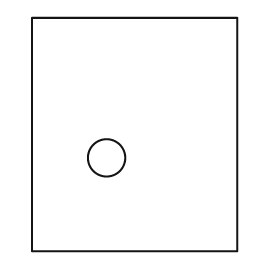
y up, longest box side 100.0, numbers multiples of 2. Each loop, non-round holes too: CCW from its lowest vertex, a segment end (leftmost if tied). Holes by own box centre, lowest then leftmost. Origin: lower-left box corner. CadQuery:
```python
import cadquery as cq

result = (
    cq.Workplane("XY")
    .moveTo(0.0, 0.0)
    .lineTo(88.0, 0.0)
    .lineTo(88.0, 100.0)
    .lineTo(0.0, 100.0)
    .close()
    .moveTo(32.0, 40.0)
    .circle(8.0)
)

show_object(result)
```